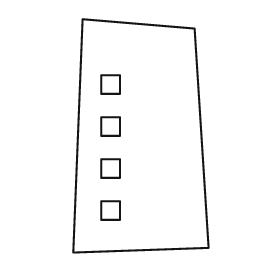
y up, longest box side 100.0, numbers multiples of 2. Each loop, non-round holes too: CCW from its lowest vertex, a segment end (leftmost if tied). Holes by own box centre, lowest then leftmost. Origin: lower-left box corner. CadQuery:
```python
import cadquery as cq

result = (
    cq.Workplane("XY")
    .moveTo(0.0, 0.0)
    .lineTo(58.0, 2.0)
    .lineTo(52.0, 96.0)
    .lineTo(4.0, 100.0)
    .close()
    .moveTo(12.0, 14.0)
    .lineTo(20.0, 14.0)
    .lineTo(20.0, 22.0)
    .lineTo(12.0, 22.0)
    .close()
    .moveTo(12.0, 32.0)
    .lineTo(20.0, 32.0)
    .lineTo(20.0, 40.0)
    .lineTo(12.0, 40.0)
    .close()
    .moveTo(12.0, 50.0)
    .lineTo(20.0, 50.0)
    .lineTo(20.0, 58.0)
    .lineTo(12.0, 58.0)
    .close()
    .moveTo(12.0, 68.0)
    .lineTo(20.0, 68.0)
    .lineTo(20.0, 76.0)
    .lineTo(12.0, 76.0)
    .close()
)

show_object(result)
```